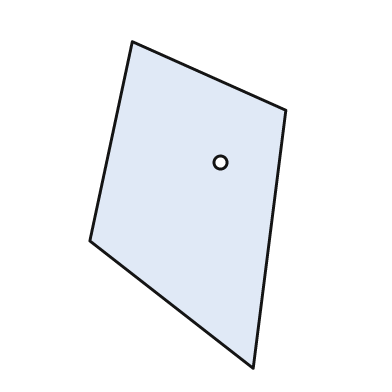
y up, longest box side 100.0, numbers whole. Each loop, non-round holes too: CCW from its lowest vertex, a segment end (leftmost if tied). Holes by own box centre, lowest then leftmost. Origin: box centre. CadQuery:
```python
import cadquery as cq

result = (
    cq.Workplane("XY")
    .moveTo(20.0, -50.0)
    .lineTo(30.0, 29.0)
    .lineTo(-17.0, 50.0)
    .lineTo(-30.0, -11.0)
    .close()
    .moveTo(10.0, 13.0)
    .circle(2.0)
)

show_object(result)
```